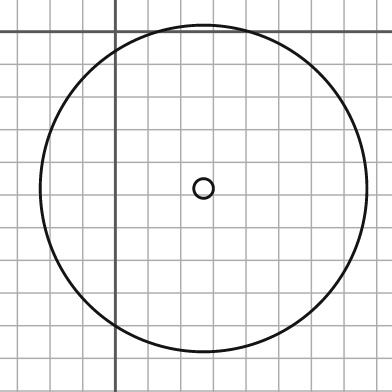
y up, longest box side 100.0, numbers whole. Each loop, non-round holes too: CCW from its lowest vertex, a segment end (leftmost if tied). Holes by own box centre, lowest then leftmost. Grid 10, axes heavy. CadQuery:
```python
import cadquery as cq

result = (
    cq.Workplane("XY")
    .moveTo(27.0, -48.0)
    .circle(50.0)
    .moveTo(27.0, -48.0)
    .circle(3.0)
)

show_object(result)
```